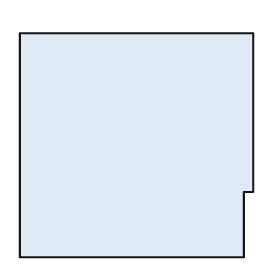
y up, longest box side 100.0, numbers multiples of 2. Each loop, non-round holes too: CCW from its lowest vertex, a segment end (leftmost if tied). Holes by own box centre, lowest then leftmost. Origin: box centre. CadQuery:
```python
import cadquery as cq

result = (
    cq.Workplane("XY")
    .moveTo(-50.0, -48.0)
    .lineTo(46.0, -48.0)
    .lineTo(46.0, -20.0)
    .lineTo(50.0, -20.0)
    .lineTo(50.0, 48.0)
    .lineTo(-50.0, 48.0)
    .close()
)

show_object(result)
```